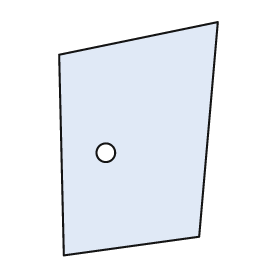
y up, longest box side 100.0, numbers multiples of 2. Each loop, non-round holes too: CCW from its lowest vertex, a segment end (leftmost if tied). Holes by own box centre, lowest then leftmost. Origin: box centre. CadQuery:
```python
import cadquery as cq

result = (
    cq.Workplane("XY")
    .moveTo(-32.0, -50.0)
    .lineTo(26.0, -42.0)
    .lineTo(34.0, 50.0)
    .lineTo(-34.0, 36.0)
    .close()
    .moveTo(-14.0, -6.0)
    .circle(4.0)
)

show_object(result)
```